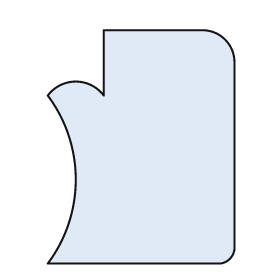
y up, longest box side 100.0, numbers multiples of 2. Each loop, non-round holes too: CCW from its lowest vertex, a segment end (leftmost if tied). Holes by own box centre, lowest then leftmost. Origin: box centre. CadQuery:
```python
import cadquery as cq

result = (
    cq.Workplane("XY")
    .moveTo(-40.0, -50.0)
    .lineTo(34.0, -50.0)
    .threePointArc((38.0, -48.0), (40.0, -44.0))
    .lineTo(40.0, 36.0)
    .threePointArc((36.0, 46.0), (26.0, 50.0))
    .lineTo(-16.0, 50.0)
    .lineTo(-16.0, 22.0)
    .threePointArc((-28.0, 28.0), (-40.0, 22.0))
    .threePointArc((-28.0, -14.0), (-40.0, -50.0))
    .close()
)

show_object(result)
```